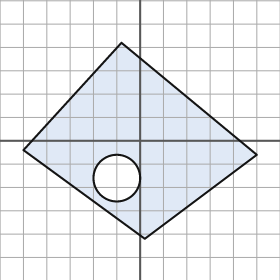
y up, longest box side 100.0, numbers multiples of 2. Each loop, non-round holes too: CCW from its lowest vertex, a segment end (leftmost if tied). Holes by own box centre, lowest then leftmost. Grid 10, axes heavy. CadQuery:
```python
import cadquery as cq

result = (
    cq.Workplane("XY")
    .moveTo(2.0, -42.0)
    .lineTo(50.0, -6.0)
    .lineTo(-8.0, 42.0)
    .lineTo(-50.0, -4.0)
    .close()
    .moveTo(-10.0, -16.0)
    .circle(10.0)
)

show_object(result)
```